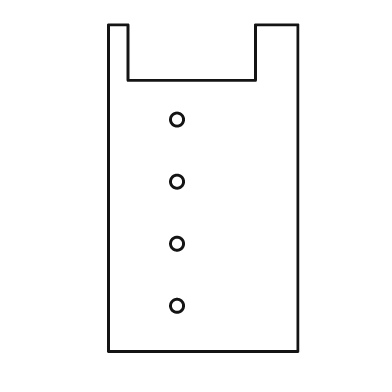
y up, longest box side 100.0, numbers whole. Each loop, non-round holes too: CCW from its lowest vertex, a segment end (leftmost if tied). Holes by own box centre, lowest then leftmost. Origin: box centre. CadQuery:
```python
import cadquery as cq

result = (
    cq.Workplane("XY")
    .moveTo(-29.0, -50.0)
    .lineTo(29.0, -50.0)
    .lineTo(29.0, 50.0)
    .lineTo(16.0, 50.0)
    .lineTo(16.0, 33.0)
    .lineTo(-23.0, 33.0)
    .lineTo(-23.0, 50.0)
    .lineTo(-29.0, 50.0)
    .close()
    .moveTo(-8.0, -36.0)
    .circle(2.0)
    .moveTo(-8.0, -17.0)
    .circle(2.0)
    .moveTo(-8.0, 2.0)
    .circle(2.0)
    .moveTo(-8.0, 21.0)
    .circle(2.0)
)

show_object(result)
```